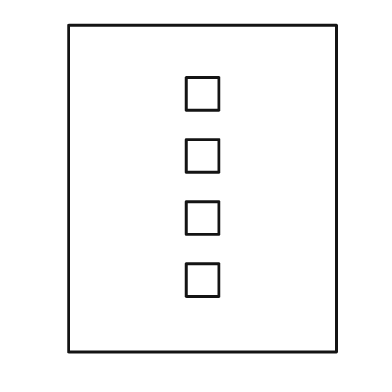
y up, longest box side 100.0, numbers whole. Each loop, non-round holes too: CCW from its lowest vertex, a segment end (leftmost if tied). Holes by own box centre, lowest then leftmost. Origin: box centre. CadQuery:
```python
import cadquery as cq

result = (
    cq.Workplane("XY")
    .moveTo(-41.0, -50.0)
    .lineTo(41.0, -50.0)
    .lineTo(41.0, 50.0)
    .lineTo(-41.0, 50.0)
    .close()
    .moveTo(-5.0, -33.0)
    .lineTo(5.0, -33.0)
    .lineTo(5.0, -23.0)
    .lineTo(-5.0, -23.0)
    .close()
    .moveTo(-5.0, -14.0)
    .lineTo(5.0, -14.0)
    .lineTo(5.0, -4.0)
    .lineTo(-5.0, -4.0)
    .close()
    .moveTo(-5.0, 5.0)
    .lineTo(5.0, 5.0)
    .lineTo(5.0, 15.0)
    .lineTo(-5.0, 15.0)
    .close()
    .moveTo(-5.0, 24.0)
    .lineTo(5.0, 24.0)
    .lineTo(5.0, 34.0)
    .lineTo(-5.0, 34.0)
    .close()
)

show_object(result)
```